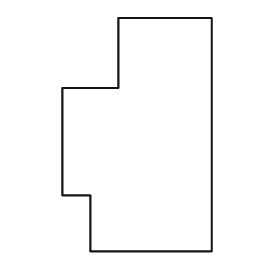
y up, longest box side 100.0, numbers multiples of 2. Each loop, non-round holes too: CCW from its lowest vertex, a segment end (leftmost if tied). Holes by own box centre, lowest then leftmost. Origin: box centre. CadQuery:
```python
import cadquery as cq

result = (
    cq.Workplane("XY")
    .moveTo(-20.0, -50.0)
    .lineTo(32.0, -50.0)
    .lineTo(32.0, 50.0)
    .lineTo(-8.0, 50.0)
    .lineTo(-8.0, 20.0)
    .lineTo(-32.0, 20.0)
    .lineTo(-32.0, -26.0)
    .lineTo(-20.0, -26.0)
    .close()
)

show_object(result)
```